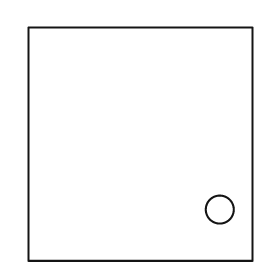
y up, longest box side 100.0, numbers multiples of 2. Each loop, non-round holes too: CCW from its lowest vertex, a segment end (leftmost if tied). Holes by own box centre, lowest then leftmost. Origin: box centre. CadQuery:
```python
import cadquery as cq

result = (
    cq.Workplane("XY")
    .moveTo(-48.0, -50.0)
    .lineTo(48.0, -50.0)
    .lineTo(48.0, 50.0)
    .lineTo(-48.0, 50.0)
    .close()
    .moveTo(34.0, -28.0)
    .circle(6.0)
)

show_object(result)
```